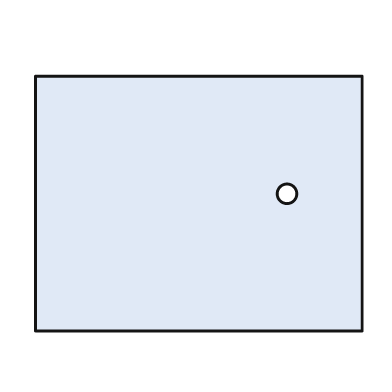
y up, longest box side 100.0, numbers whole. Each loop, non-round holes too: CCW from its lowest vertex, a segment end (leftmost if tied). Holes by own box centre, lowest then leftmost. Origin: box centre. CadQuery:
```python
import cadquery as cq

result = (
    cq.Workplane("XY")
    .moveTo(-50.0, -39.0)
    .lineTo(50.0, -39.0)
    .lineTo(50.0, 39.0)
    .lineTo(-50.0, 39.0)
    .close()
    .moveTo(27.0, 3.0)
    .circle(3.0)
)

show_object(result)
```